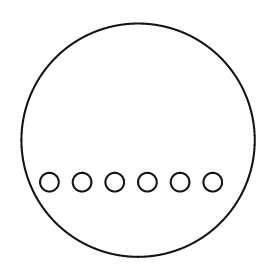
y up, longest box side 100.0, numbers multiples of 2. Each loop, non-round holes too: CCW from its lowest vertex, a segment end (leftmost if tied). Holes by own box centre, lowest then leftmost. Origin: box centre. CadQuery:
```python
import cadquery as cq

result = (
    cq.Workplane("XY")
    .moveTo(0.0, 0.0)
    .circle(50.0)
    .moveTo(-38.0, -18.0)
    .circle(4.0)
    .moveTo(-24.0, -18.0)
    .circle(4.0)
    .moveTo(-10.0, -18.0)
    .circle(4.0)
    .moveTo(4.0, -18.0)
    .circle(4.0)
    .moveTo(18.0, -18.0)
    .circle(4.0)
    .moveTo(32.0, -18.0)
    .circle(4.0)
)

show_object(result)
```